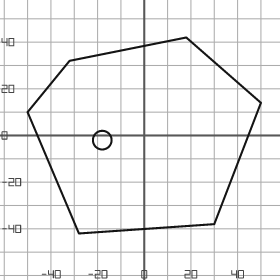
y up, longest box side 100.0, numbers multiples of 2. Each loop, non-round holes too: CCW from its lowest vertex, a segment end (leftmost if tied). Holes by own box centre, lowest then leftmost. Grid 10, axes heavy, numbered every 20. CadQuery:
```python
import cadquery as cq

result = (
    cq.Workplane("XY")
    .moveTo(-28.0, -42.0)
    .lineTo(30.0, -38.0)
    .lineTo(50.0, 14.0)
    .lineTo(18.0, 42.0)
    .lineTo(-32.0, 32.0)
    .lineTo(-50.0, 10.0)
    .close()
    .moveTo(-18.0, -2.0)
    .circle(4.0)
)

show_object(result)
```